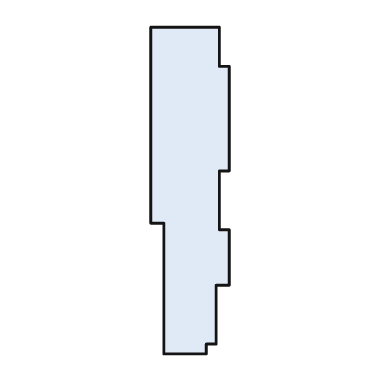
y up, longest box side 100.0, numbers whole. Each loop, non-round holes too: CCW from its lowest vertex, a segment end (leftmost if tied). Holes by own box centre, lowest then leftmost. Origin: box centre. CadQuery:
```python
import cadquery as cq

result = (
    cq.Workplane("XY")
    .moveTo(-8.0, -50.0)
    .lineTo(5.0, -50.0)
    .lineTo(5.0, -47.0)
    .lineTo(8.0, -47.0)
    .lineTo(8.0, -29.0)
    .lineTo(12.0, -29.0)
    .lineTo(12.0, -12.0)
    .lineTo(9.0, -12.0)
    .lineTo(9.0, 6.0)
    .lineTo(12.0, 6.0)
    .lineTo(12.0, 38.0)
    .lineTo(9.0, 38.0)
    .lineTo(9.0, 50.0)
    .lineTo(-12.0, 50.0)
    .lineTo(-12.0, -10.0)
    .lineTo(-8.0, -10.0)
    .close()
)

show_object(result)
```